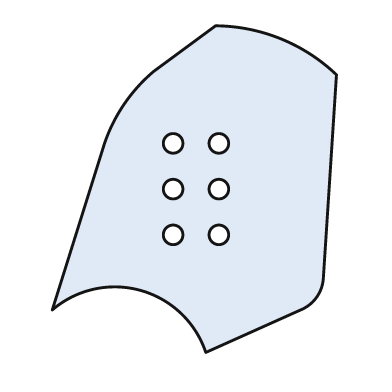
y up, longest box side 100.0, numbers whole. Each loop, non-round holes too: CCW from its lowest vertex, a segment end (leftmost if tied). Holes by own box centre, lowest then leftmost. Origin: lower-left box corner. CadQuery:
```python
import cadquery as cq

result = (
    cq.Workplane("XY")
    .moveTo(47.0, 0.0)
    .lineTo(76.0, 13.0)
    .threePointArc((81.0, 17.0), (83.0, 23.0))
    .lineTo(87.0, 85.0)
    .threePointArc((70.0, 96.0), (50.0, 100.0))
    .lineTo(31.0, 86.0)
    .threePointArc((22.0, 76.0), (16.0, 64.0))
    .lineTo(0.0, 13.0)
    .threePointArc((27.0, 19.0), (47.0, 0.0))
    .close()
    .moveTo(37.0, 36.0)
    .circle(3.0)
    .moveTo(51.0, 36.0)
    .circle(3.0)
    .moveTo(37.0, 50.0)
    .circle(3.0)
    .moveTo(51.0, 50.0)
    .circle(3.0)
    .moveTo(37.0, 64.0)
    .circle(3.0)
    .moveTo(51.0, 64.0)
    .circle(3.0)
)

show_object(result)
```